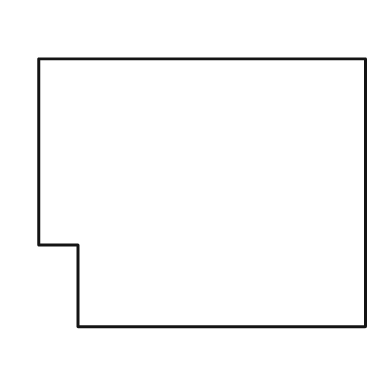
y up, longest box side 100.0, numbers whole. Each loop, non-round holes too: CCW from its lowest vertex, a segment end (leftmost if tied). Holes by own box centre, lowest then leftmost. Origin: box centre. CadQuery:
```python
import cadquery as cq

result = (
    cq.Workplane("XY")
    .moveTo(-38.0, -41.0)
    .lineTo(50.0, -41.0)
    .lineTo(50.0, 41.0)
    .lineTo(-50.0, 41.0)
    .lineTo(-50.0, -16.0)
    .lineTo(-38.0, -16.0)
    .close()
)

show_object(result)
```